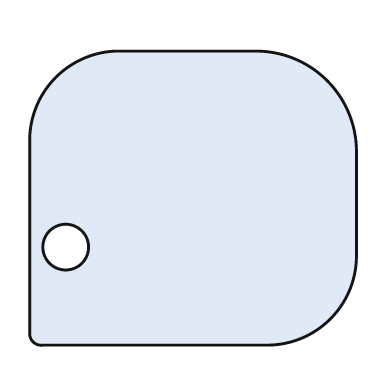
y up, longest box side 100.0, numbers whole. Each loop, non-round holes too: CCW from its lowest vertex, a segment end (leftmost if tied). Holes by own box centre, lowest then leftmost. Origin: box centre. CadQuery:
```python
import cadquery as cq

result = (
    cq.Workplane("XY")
    .moveTo(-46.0, -45.0)
    .lineTo(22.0, -45.0)
    .threePointArc((42.0, -37.0), (50.0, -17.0))
    .lineTo(50.0, 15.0)
    .threePointArc((41.0, 36.0), (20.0, 45.0))
    .lineTo(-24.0, 45.0)
    .threePointArc((-42.0, 37.0), (-50.0, 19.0))
    .lineTo(-50.0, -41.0)
    .threePointArc((-49.0, -44.0), (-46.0, -45.0))
    .close()
    .moveTo(-39.0, -15.0)
    .circle(7.0)
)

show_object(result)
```